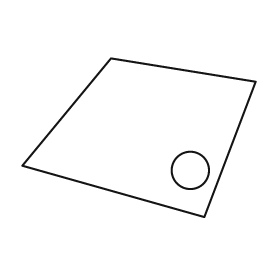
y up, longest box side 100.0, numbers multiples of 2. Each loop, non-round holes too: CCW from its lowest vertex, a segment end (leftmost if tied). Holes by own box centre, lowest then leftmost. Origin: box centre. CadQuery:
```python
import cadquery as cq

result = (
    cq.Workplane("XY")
    .moveTo(28.0, -34.0)
    .lineTo(50.0, 24.0)
    .lineTo(-12.0, 34.0)
    .lineTo(-50.0, -12.0)
    .close()
    .moveTo(22.0, -14.0)
    .circle(8.0)
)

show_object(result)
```